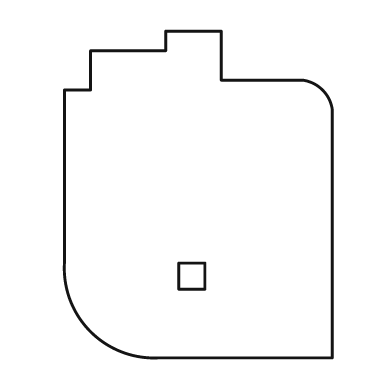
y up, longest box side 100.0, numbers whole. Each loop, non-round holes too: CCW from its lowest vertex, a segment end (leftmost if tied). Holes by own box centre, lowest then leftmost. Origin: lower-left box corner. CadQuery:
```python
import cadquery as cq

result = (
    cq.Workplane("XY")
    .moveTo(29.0, 0.0)
    .lineTo(82.0, 0.0)
    .lineTo(82.0, 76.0)
    .threePointArc((79.0, 82.0), (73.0, 85.0))
    .lineTo(48.0, 85.0)
    .lineTo(48.0, 100.0)
    .lineTo(31.0, 100.0)
    .lineTo(31.0, 94.0)
    .lineTo(8.0, 94.0)
    .lineTo(8.0, 82.0)
    .lineTo(0.0, 82.0)
    .lineTo(0.0, 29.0)
    .threePointArc((8.0, 8.0), (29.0, 0.0))
    .close()
    .moveTo(35.0, 21.0)
    .lineTo(43.0, 21.0)
    .lineTo(43.0, 29.0)
    .lineTo(35.0, 29.0)
    .close()
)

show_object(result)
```